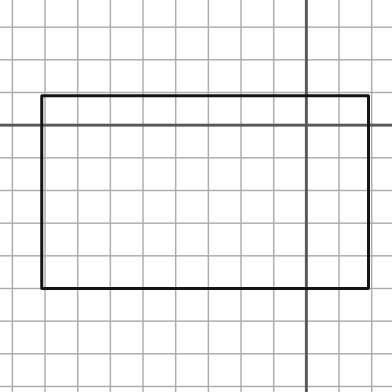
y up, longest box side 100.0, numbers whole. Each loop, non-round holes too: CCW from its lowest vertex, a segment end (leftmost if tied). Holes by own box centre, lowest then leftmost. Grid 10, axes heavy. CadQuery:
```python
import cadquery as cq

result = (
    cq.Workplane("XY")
    .moveTo(-81.0, -50.0)
    .lineTo(19.0, -50.0)
    .lineTo(19.0, 9.0)
    .lineTo(-81.0, 9.0)
    .close()
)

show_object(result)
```